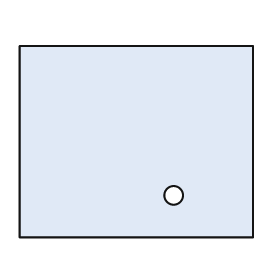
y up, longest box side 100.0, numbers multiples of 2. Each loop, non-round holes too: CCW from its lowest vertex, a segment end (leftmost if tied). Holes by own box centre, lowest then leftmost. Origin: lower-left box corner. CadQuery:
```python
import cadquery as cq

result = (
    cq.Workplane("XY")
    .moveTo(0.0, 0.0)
    .lineTo(100.0, 0.0)
    .lineTo(100.0, 82.0)
    .lineTo(0.0, 82.0)
    .close()
    .moveTo(66.0, 18.0)
    .circle(4.0)
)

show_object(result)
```